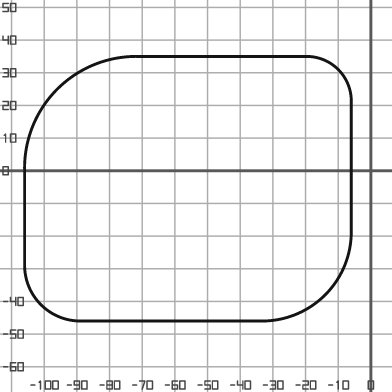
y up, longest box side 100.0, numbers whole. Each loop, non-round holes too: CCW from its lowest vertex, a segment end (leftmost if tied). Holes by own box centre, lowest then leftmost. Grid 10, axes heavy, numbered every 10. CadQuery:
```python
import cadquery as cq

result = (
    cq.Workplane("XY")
    .moveTo(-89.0, -46.0)
    .lineTo(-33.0, -46.0)
    .threePointArc((-14.0, -38.0), (-6.0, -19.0))
    .lineTo(-6.0, 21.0)
    .threePointArc((-10.0, 31.0), (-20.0, 35.0))
    .lineTo(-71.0, 35.0)
    .threePointArc((-96.0, 25.0), (-106.0, 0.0))
    .lineTo(-106.0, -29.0)
    .threePointArc((-101.0, -41.0), (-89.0, -46.0))
    .close()
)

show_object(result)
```